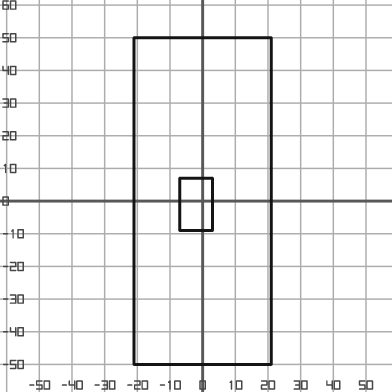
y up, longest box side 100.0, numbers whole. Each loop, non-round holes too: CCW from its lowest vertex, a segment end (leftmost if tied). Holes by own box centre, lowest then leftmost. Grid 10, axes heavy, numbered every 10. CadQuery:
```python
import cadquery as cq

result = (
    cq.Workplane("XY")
    .moveTo(-21.0, -50.0)
    .lineTo(21.0, -50.0)
    .lineTo(21.0, 50.0)
    .lineTo(-21.0, 50.0)
    .close()
    .moveTo(-7.0, -9.0)
    .lineTo(3.0, -9.0)
    .lineTo(3.0, 7.0)
    .lineTo(-7.0, 7.0)
    .close()
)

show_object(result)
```